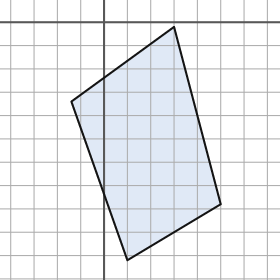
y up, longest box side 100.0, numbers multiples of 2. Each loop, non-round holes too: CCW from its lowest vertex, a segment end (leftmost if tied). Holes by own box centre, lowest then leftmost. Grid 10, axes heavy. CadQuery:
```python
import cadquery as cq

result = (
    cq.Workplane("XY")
    .moveTo(10.0, -102.0)
    .lineTo(50.0, -78.0)
    .lineTo(30.0, -2.0)
    .lineTo(-14.0, -34.0)
    .close()
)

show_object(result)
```